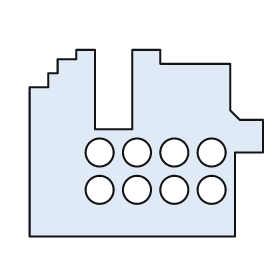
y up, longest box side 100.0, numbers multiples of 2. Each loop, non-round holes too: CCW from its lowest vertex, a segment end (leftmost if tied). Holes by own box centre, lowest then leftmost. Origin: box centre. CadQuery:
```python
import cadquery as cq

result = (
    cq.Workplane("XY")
    .moveTo(-50.0, -40.0)
    .lineTo(38.0, -40.0)
    .lineTo(38.0, -4.0)
    .lineTo(50.0, -4.0)
    .lineTo(50.0, 10.0)
    .lineTo(40.0, 10.0)
    .lineTo(36.0, 14.0)
    .lineTo(36.0, 34.0)
    .lineTo(6.0, 34.0)
    .lineTo(6.0, 40.0)
    .lineTo(-6.0, 40.0)
    .lineTo(-6.0, 6.0)
    .lineTo(-22.0, 6.0)
    .lineTo(-22.0, 40.0)
    .lineTo(-30.0, 40.0)
    .lineTo(-30.0, 36.0)
    .lineTo(-38.0, 36.0)
    .lineTo(-38.0, 30.0)
    .lineTo(-42.0, 30.0)
    .lineTo(-42.0, 24.0)
    .lineTo(-50.0, 24.0)
    .close()
    .moveTo(-20.0, -20.0)
    .circle(6.0)
    .moveTo(-4.0, -20.0)
    .circle(6.0)
    .moveTo(12.0, -20.0)
    .circle(6.0)
    .moveTo(28.0, -20.0)
    .circle(6.0)
    .moveTo(-20.0, -4.0)
    .circle(6.0)
    .moveTo(-4.0, -4.0)
    .circle(6.0)
    .moveTo(12.0, -4.0)
    .circle(6.0)
    .moveTo(28.0, -4.0)
    .circle(6.0)
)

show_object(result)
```